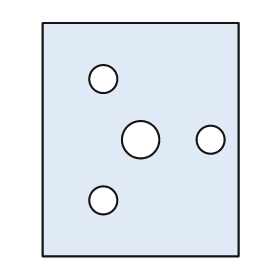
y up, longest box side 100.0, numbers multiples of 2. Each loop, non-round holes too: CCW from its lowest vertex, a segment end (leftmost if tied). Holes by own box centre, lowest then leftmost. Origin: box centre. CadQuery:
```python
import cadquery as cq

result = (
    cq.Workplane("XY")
    .moveTo(-42.0, -50.0)
    .lineTo(42.0, -50.0)
    .lineTo(42.0, 50.0)
    .lineTo(-42.0, 50.0)
    .close()
    .moveTo(-16.0, -26.0)
    .circle(6.0)
    .moveTo(0.0, 0.0)
    .circle(8.0)
    .moveTo(30.0, 0.0)
    .circle(6.0)
    .moveTo(-16.0, 26.0)
    .circle(6.0)
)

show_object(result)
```